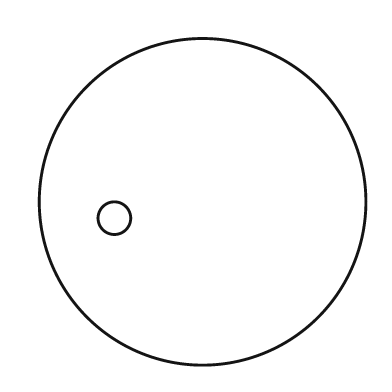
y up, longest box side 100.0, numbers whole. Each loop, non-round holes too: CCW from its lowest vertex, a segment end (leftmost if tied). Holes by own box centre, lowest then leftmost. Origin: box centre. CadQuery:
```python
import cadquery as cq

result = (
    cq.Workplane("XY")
    .moveTo(0.0, 0.0)
    .circle(50.0)
    .moveTo(-27.0, -5.0)
    .circle(5.0)
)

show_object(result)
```